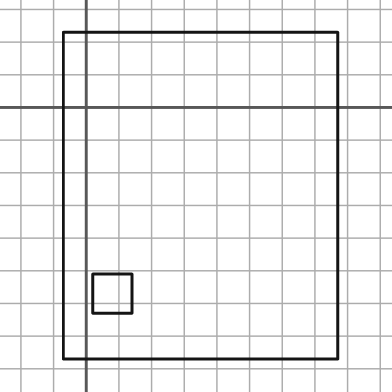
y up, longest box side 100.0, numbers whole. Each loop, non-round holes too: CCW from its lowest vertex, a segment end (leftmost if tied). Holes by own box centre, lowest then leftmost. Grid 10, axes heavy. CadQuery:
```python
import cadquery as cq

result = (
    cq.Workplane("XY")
    .moveTo(-7.0, -77.0)
    .lineTo(77.0, -77.0)
    .lineTo(77.0, 23.0)
    .lineTo(-7.0, 23.0)
    .close()
    .moveTo(2.0, -63.0)
    .lineTo(14.0, -63.0)
    .lineTo(14.0, -51.0)
    .lineTo(2.0, -51.0)
    .close()
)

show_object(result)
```